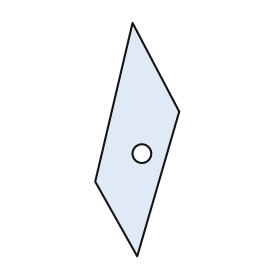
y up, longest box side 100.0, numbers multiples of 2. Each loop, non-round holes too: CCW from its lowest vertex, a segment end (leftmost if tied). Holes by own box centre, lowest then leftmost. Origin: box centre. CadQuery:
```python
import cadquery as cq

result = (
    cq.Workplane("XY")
    .moveTo(0.0, -50.0)
    .lineTo(18.0, 12.0)
    .lineTo(-2.0, 50.0)
    .lineTo(-18.0, -18.0)
    .close()
    .moveTo(2.0, -6.0)
    .circle(4.0)
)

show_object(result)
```